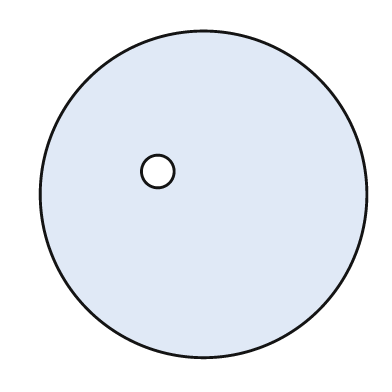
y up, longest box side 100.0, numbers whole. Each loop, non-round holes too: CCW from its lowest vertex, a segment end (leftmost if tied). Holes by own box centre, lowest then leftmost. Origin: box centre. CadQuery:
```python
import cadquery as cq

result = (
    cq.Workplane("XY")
    .moveTo(0.0, 0.0)
    .circle(50.0)
    .moveTo(-14.0, 7.0)
    .circle(5.0)
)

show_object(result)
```